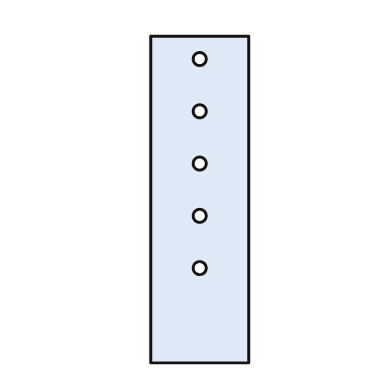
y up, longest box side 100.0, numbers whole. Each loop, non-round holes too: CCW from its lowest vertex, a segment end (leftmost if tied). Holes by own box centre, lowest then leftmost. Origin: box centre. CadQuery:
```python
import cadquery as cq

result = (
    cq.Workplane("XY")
    .moveTo(-15.0, -50.0)
    .lineTo(15.0, -50.0)
    .lineTo(15.0, 50.0)
    .lineTo(-15.0, 50.0)
    .close()
    .moveTo(0.0, -21.0)
    .circle(2.0)
    .moveTo(0.0, -5.0)
    .circle(2.0)
    .moveTo(0.0, 11.0)
    .circle(2.0)
    .moveTo(0.0, 27.0)
    .circle(2.0)
    .moveTo(0.0, 43.0)
    .circle(2.0)
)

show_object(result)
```